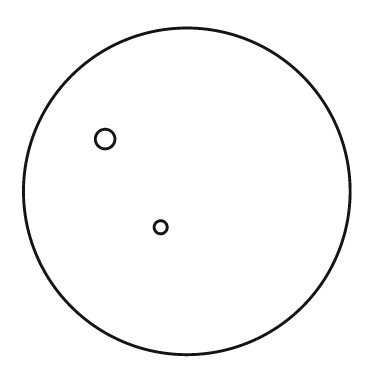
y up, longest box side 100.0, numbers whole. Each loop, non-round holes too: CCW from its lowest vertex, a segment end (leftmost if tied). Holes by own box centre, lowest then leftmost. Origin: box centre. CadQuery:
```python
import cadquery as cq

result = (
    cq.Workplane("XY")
    .moveTo(0.0, 0.0)
    .circle(50.0)
    .moveTo(-8.0, -11.0)
    .circle(2.0)
    .moveTo(-25.0, 16.0)
    .circle(3.0)
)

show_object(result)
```